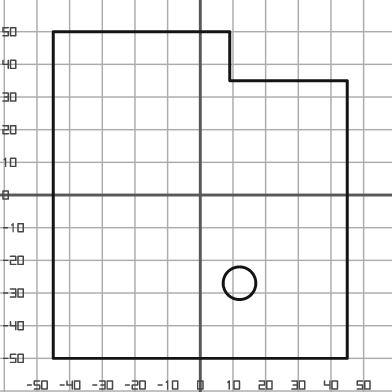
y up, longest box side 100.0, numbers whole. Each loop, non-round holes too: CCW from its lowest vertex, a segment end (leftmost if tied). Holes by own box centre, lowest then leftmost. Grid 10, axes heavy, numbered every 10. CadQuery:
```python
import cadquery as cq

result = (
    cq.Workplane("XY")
    .moveTo(-45.0, -50.0)
    .lineTo(45.0, -50.0)
    .lineTo(45.0, 35.0)
    .lineTo(9.0, 35.0)
    .lineTo(9.0, 50.0)
    .lineTo(-45.0, 50.0)
    .close()
    .moveTo(12.0, -27.0)
    .circle(5.0)
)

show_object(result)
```